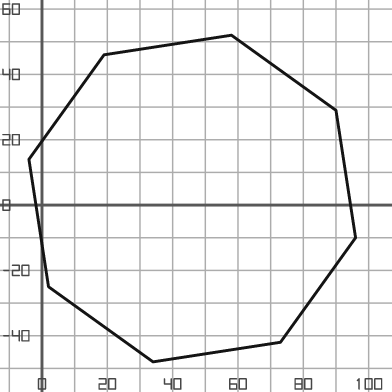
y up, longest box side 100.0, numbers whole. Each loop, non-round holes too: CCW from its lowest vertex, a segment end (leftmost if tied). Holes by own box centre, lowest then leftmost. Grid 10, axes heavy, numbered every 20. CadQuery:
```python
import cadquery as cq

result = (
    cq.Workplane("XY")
    .moveTo(34.0, -48.0)
    .lineTo(73.0, -42.0)
    .lineTo(96.0, -10.0)
    .lineTo(90.0, 29.0)
    .lineTo(58.0, 52.0)
    .lineTo(19.0, 46.0)
    .lineTo(-4.0, 14.0)
    .lineTo(2.0, -25.0)
    .close()
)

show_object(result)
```